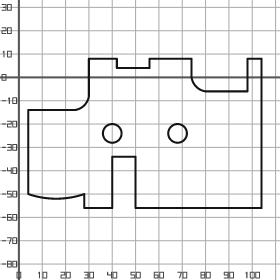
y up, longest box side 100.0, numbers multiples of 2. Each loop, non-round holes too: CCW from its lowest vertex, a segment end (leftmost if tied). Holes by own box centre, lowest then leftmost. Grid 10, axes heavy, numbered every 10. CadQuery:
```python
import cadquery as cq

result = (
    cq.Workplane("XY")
    .moveTo(28.0, -56.0)
    .lineTo(40.0, -56.0)
    .lineTo(40.0, -34.0)
    .lineTo(50.0, -34.0)
    .lineTo(50.0, -56.0)
    .lineTo(104.0, -56.0)
    .lineTo(104.0, 8.0)
    .lineTo(98.0, 8.0)
    .lineTo(98.0, -6.0)
    .lineTo(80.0, -6.0)
    .threePointArc((76.0, -4.0), (74.0, 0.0))
    .lineTo(74.0, 8.0)
    .lineTo(56.0, 8.0)
    .lineTo(56.0, 4.0)
    .lineTo(42.0, 4.0)
    .lineTo(42.0, 8.0)
    .lineTo(30.0, 8.0)
    .lineTo(30.0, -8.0)
    .threePointArc((28.0, -12.0), (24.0, -14.0))
    .lineTo(4.0, -14.0)
    .lineTo(4.0, -50.0)
    .threePointArc((16.0, -52.0), (28.0, -50.0))
    .close()
    .moveTo(40.0, -24.0)
    .circle(4.0)
    .moveTo(68.0, -24.0)
    .circle(4.0)
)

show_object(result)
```